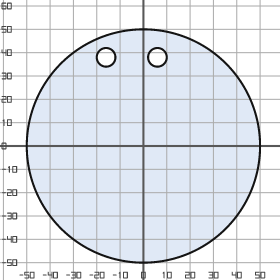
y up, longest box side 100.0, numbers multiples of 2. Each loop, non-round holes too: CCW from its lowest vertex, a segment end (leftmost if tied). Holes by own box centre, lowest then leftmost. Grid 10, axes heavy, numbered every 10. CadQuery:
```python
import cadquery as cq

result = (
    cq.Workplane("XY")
    .moveTo(0.0, 0.0)
    .circle(50.0)
    .moveTo(-16.0, 38.0)
    .circle(4.0)
    .moveTo(6.0, 38.0)
    .circle(4.0)
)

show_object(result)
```